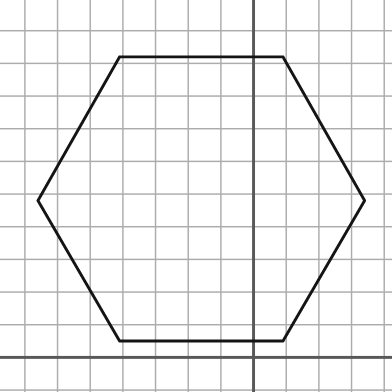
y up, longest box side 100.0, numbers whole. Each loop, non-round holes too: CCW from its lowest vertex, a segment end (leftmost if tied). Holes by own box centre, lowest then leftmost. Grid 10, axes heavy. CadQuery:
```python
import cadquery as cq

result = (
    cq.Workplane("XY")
    .moveTo(-41.0, 5.0)
    .lineTo(9.0, 5.0)
    .lineTo(34.0, 48.0)
    .lineTo(9.0, 92.0)
    .lineTo(-41.0, 92.0)
    .lineTo(-66.0, 48.0)
    .close()
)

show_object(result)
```